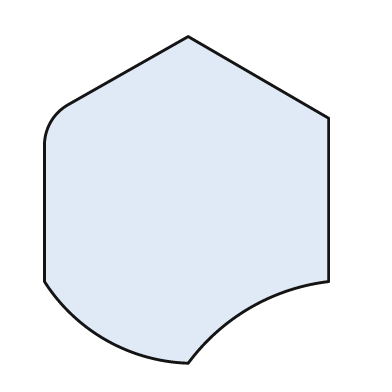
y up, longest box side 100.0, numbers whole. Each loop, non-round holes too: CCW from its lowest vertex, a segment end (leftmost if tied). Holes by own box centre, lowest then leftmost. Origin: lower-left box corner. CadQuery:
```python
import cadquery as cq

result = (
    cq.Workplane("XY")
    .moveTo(44.0, 0.0)
    .threePointArc((63.0, 17.0), (87.0, 25.0))
    .lineTo(87.0, 75.0)
    .lineTo(44.0, 100.0)
    .lineTo(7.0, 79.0)
    .threePointArc((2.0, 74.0), (0.0, 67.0))
    .lineTo(0.0, 25.0)
    .threePointArc((19.0, 7.0), (44.0, 0.0))
    .close()
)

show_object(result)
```